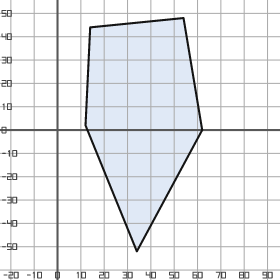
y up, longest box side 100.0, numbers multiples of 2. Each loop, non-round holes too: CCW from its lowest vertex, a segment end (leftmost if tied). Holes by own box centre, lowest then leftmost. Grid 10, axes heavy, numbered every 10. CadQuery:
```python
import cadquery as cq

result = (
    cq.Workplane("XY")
    .moveTo(34.0, -52.0)
    .lineTo(62.0, 0.0)
    .lineTo(54.0, 48.0)
    .lineTo(14.0, 44.0)
    .lineTo(12.0, 2.0)
    .close()
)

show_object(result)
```